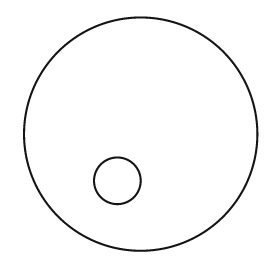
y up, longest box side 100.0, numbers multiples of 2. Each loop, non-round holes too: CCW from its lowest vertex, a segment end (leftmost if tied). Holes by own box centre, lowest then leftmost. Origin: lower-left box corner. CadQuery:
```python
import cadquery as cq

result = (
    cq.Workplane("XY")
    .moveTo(50.0, 50.0)
    .circle(50.0)
    .moveTo(40.0, 30.0)
    .circle(10.0)
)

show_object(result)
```